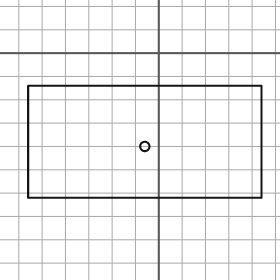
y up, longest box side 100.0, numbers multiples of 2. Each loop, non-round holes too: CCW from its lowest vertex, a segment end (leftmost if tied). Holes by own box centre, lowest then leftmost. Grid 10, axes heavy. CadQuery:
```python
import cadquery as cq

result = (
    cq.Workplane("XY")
    .moveTo(-56.0, -62.0)
    .lineTo(44.0, -62.0)
    .lineTo(44.0, -14.0)
    .lineTo(-56.0, -14.0)
    .close()
    .moveTo(-6.0, -40.0)
    .circle(2.0)
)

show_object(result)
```